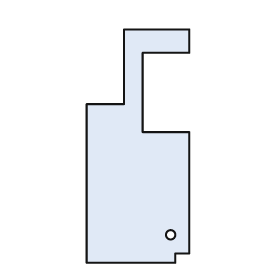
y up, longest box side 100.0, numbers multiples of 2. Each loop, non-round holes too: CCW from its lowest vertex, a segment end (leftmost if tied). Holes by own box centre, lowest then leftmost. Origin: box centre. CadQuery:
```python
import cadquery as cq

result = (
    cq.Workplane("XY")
    .moveTo(-22.0, -50.0)
    .lineTo(16.0, -50.0)
    .lineTo(16.0, -46.0)
    .lineTo(22.0, -46.0)
    .lineTo(22.0, 6.0)
    .lineTo(2.0, 6.0)
    .lineTo(2.0, 40.0)
    .lineTo(22.0, 40.0)
    .lineTo(22.0, 50.0)
    .lineTo(-6.0, 50.0)
    .lineTo(-6.0, 18.0)
    .lineTo(-22.0, 18.0)
    .close()
    .moveTo(14.0, -38.0)
    .circle(2.0)
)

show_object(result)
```